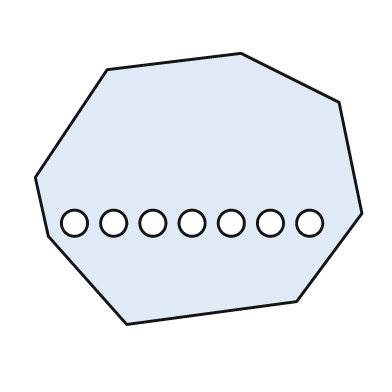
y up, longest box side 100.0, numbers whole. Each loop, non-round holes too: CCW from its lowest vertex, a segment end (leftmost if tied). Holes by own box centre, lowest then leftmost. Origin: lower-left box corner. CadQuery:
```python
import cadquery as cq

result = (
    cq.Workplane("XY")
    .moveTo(28.0, 0.0)
    .lineTo(80.0, 7.0)
    .lineTo(100.0, 34.0)
    .lineTo(93.0, 68.0)
    .lineTo(63.0, 83.0)
    .lineTo(22.0, 78.0)
    .lineTo(0.0, 45.0)
    .lineTo(4.0, 27.0)
    .close()
    .moveTo(12.0, 31.0)
    .circle(4.0)
    .moveTo(24.0, 31.0)
    .circle(4.0)
    .moveTo(36.0, 31.0)
    .circle(4.0)
    .moveTo(48.0, 31.0)
    .circle(4.0)
    .moveTo(60.0, 31.0)
    .circle(4.0)
    .moveTo(72.0, 31.0)
    .circle(4.0)
    .moveTo(84.0, 31.0)
    .circle(4.0)
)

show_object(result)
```